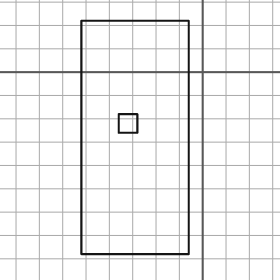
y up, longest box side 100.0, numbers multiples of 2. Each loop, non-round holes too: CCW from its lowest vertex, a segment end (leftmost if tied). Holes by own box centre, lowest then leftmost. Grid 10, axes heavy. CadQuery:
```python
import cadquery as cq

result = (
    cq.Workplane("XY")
    .moveTo(-52.0, -78.0)
    .lineTo(-6.0, -78.0)
    .lineTo(-6.0, 22.0)
    .lineTo(-52.0, 22.0)
    .close()
    .moveTo(-36.0, -26.0)
    .lineTo(-28.0, -26.0)
    .lineTo(-28.0, -18.0)
    .lineTo(-36.0, -18.0)
    .close()
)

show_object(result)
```